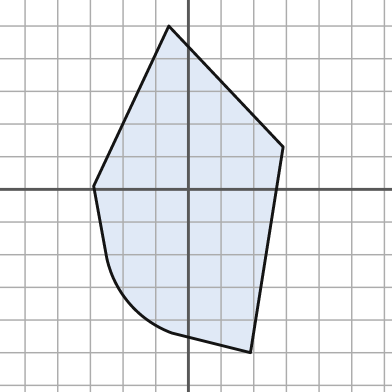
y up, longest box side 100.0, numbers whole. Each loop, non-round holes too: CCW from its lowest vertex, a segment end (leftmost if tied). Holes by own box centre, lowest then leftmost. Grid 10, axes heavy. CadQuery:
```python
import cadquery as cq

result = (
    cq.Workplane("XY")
    .moveTo(19.0, -50.0)
    .lineTo(29.0, 13.0)
    .lineTo(-6.0, 50.0)
    .lineTo(-29.0, 1.0)
    .lineTo(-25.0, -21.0)
    .threePointArc((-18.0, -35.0), (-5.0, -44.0))
    .close()
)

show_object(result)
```